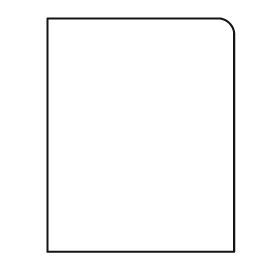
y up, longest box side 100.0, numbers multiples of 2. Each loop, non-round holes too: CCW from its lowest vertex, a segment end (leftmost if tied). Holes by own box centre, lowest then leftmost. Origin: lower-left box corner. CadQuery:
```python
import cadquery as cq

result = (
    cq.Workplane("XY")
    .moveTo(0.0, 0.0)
    .lineTo(80.0, 0.0)
    .lineTo(80.0, 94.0)
    .threePointArc((78.0, 98.0), (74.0, 100.0))
    .lineTo(0.0, 100.0)
    .close()
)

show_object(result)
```